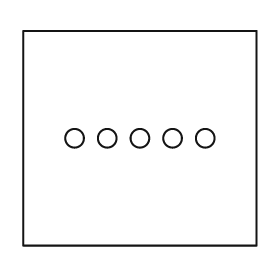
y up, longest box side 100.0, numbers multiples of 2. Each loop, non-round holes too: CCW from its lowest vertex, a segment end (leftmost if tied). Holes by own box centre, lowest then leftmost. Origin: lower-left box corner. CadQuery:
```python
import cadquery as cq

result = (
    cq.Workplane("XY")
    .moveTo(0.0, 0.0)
    .lineTo(100.0, 0.0)
    .lineTo(100.0, 92.0)
    .lineTo(0.0, 92.0)
    .close()
    .moveTo(22.0, 46.0)
    .circle(4.0)
    .moveTo(36.0, 46.0)
    .circle(4.0)
    .moveTo(50.0, 46.0)
    .circle(4.0)
    .moveTo(64.0, 46.0)
    .circle(4.0)
    .moveTo(78.0, 46.0)
    .circle(4.0)
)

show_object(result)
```